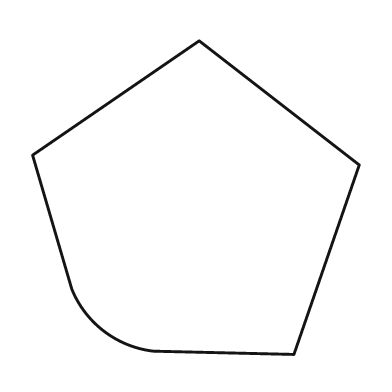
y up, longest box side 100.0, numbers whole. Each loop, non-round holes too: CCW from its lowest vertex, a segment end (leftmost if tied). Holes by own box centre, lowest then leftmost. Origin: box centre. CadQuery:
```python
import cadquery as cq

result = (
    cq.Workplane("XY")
    .moveTo(30.0, -48.0)
    .lineTo(50.0, 10.0)
    .lineTo(1.0, 48.0)
    .lineTo(-50.0, 13.0)
    .lineTo(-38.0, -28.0)
    .threePointArc((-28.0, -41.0), (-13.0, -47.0))
    .close()
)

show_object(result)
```